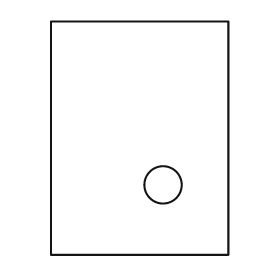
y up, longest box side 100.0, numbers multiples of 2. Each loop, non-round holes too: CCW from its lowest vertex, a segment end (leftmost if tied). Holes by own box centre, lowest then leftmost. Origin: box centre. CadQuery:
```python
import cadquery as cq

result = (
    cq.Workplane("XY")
    .moveTo(-38.0, -50.0)
    .lineTo(38.0, -50.0)
    .lineTo(38.0, 50.0)
    .lineTo(-38.0, 50.0)
    .close()
    .moveTo(10.0, -20.0)
    .circle(8.0)
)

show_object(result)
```